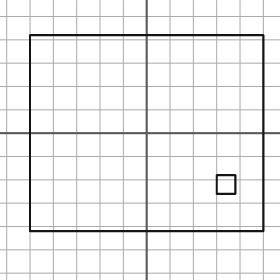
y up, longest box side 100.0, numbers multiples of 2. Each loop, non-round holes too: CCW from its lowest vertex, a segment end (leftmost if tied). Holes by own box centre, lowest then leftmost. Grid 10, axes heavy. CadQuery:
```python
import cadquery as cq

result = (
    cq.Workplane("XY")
    .moveTo(-50.0, -42.0)
    .lineTo(50.0, -42.0)
    .lineTo(50.0, 42.0)
    .lineTo(-50.0, 42.0)
    .close()
    .moveTo(30.0, -26.0)
    .lineTo(38.0, -26.0)
    .lineTo(38.0, -18.0)
    .lineTo(30.0, -18.0)
    .close()
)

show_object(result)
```